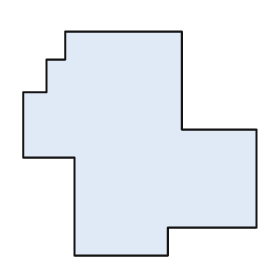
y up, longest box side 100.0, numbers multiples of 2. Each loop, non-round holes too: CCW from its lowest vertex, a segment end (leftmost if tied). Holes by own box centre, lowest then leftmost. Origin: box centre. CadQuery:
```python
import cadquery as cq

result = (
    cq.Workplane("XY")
    .moveTo(-28.0, -48.0)
    .lineTo(12.0, -48.0)
    .lineTo(12.0, -36.0)
    .lineTo(50.0, -36.0)
    .lineTo(50.0, 6.0)
    .lineTo(18.0, 6.0)
    .lineTo(18.0, 48.0)
    .lineTo(-32.0, 48.0)
    .lineTo(-32.0, 36.0)
    .lineTo(-40.0, 36.0)
    .lineTo(-40.0, 22.0)
    .lineTo(-50.0, 22.0)
    .lineTo(-50.0, -6.0)
    .lineTo(-28.0, -6.0)
    .close()
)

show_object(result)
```